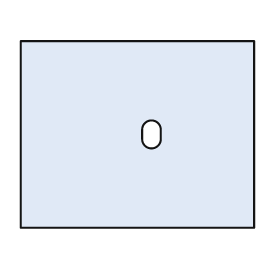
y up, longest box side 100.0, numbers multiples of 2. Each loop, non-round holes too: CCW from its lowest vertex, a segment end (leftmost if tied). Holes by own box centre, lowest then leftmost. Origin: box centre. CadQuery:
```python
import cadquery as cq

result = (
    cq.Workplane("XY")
    .moveTo(-50.0, -40.0)
    .lineTo(50.0, -40.0)
    .lineTo(50.0, 40.0)
    .lineTo(-50.0, 40.0)
    .close()
    .moveTo(2.0, -2.0)
    .threePointArc((6.0, -6.0), (10.0, -2.0))
    .lineTo(10.0, 2.0)
    .threePointArc((6.0, 6.0), (2.0, 2.0))
    .close()
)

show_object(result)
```